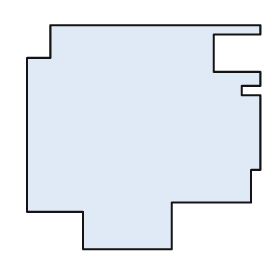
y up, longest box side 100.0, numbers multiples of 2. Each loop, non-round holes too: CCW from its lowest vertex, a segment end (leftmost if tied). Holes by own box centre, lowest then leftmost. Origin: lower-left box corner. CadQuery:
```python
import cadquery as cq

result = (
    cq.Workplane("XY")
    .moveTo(24.0, 0.0)
    .lineTo(62.0, 0.0)
    .lineTo(62.0, 20.0)
    .lineTo(96.0, 20.0)
    .lineTo(96.0, 34.0)
    .lineTo(100.0, 34.0)
    .lineTo(100.0, 66.0)
    .lineTo(92.0, 66.0)
    .lineTo(92.0, 70.0)
    .lineTo(100.0, 70.0)
    .lineTo(100.0, 76.0)
    .lineTo(80.0, 76.0)
    .lineTo(80.0, 92.0)
    .lineTo(100.0, 92.0)
    .lineTo(100.0, 96.0)
    .lineTo(10.0, 96.0)
    .lineTo(10.0, 82.0)
    .lineTo(0.0, 82.0)
    .lineTo(0.0, 16.0)
    .lineTo(24.0, 16.0)
    .close()
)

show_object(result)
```